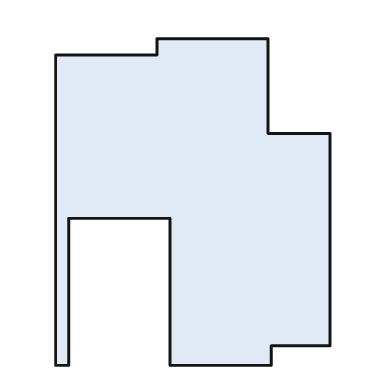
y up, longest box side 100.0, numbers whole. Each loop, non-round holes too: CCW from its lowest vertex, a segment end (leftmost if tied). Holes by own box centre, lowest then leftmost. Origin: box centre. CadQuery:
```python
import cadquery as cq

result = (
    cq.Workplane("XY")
    .moveTo(-42.0, -50.0)
    .lineTo(-38.0, -50.0)
    .lineTo(-38.0, -5.0)
    .lineTo(-7.0, -5.0)
    .lineTo(-7.0, -50.0)
    .lineTo(24.0, -50.0)
    .lineTo(24.0, -44.0)
    .lineTo(42.0, -44.0)
    .lineTo(42.0, 21.0)
    .lineTo(23.0, 21.0)
    .lineTo(23.0, 50.0)
    .lineTo(-11.0, 50.0)
    .lineTo(-11.0, 45.0)
    .lineTo(-42.0, 45.0)
    .close()
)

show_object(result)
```